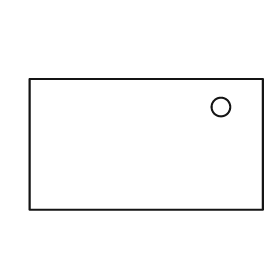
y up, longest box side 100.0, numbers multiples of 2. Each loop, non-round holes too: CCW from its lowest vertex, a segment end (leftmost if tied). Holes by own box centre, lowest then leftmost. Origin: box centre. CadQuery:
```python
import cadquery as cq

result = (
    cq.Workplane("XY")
    .moveTo(-50.0, -28.0)
    .lineTo(50.0, -28.0)
    .lineTo(50.0, 28.0)
    .lineTo(-50.0, 28.0)
    .close()
    .moveTo(32.0, 16.0)
    .circle(4.0)
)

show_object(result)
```